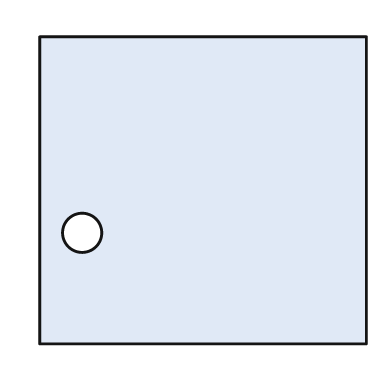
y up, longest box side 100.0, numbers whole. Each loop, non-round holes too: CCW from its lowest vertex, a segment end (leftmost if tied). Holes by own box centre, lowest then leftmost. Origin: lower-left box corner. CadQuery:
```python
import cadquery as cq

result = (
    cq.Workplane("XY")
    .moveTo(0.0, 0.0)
    .lineTo(100.0, 0.0)
    .lineTo(100.0, 94.0)
    .lineTo(0.0, 94.0)
    .close()
    .moveTo(13.0, 34.0)
    .circle(6.0)
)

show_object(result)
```